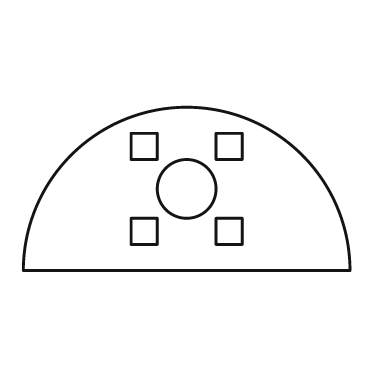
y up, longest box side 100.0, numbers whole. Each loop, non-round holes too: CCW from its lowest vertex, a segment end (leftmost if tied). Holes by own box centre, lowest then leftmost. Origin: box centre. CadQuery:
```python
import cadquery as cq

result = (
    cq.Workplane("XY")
    .moveTo(-50.0, -25.0)
    .lineTo(50.0, -25.0)
    .threePointArc((0.0, 25.0), (-50.0, -25.0))
    .close()
    .moveTo(-17.0, -17.0)
    .lineTo(-9.0, -17.0)
    .lineTo(-9.0, -9.0)
    .lineTo(-17.0, -9.0)
    .close()
    .moveTo(9.0, -17.0)
    .lineTo(17.0, -17.0)
    .lineTo(17.0, -9.0)
    .lineTo(9.0, -9.0)
    .close()
    .moveTo(0.0, 0.0)
    .circle(9.0)
    .moveTo(-17.0, 9.0)
    .lineTo(-9.0, 9.0)
    .lineTo(-9.0, 17.0)
    .lineTo(-17.0, 17.0)
    .close()
    .moveTo(9.0, 9.0)
    .lineTo(17.0, 9.0)
    .lineTo(17.0, 17.0)
    .lineTo(9.0, 17.0)
    .close()
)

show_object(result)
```